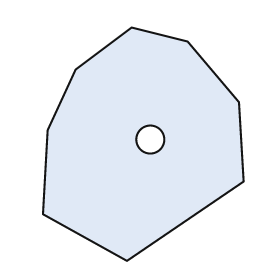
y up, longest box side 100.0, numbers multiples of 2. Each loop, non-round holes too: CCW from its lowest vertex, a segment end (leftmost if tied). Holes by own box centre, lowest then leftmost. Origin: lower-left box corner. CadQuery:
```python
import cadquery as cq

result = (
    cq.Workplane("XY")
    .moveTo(36.0, 0.0)
    .lineTo(86.0, 34.0)
    .lineTo(84.0, 68.0)
    .lineTo(62.0, 94.0)
    .lineTo(38.0, 100.0)
    .lineTo(14.0, 82.0)
    .lineTo(2.0, 56.0)
    .lineTo(0.0, 20.0)
    .close()
    .moveTo(46.0, 52.0)
    .circle(6.0)
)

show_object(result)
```